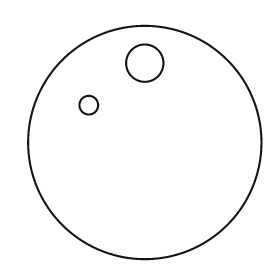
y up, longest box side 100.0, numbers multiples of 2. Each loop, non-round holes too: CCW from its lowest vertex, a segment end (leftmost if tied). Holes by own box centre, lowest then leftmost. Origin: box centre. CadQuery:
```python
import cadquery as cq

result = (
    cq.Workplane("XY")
    .moveTo(0.0, 0.0)
    .circle(50.0)
    .moveTo(-24.0, 16.0)
    .circle(4.0)
    .moveTo(0.0, 34.0)
    .circle(8.0)
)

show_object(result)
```